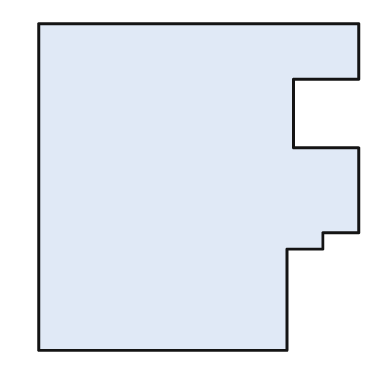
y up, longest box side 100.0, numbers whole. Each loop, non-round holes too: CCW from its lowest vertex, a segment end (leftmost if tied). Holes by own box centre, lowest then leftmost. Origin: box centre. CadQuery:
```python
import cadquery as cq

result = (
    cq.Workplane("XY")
    .moveTo(-49.0, -50.0)
    .lineTo(27.0, -50.0)
    .lineTo(27.0, -19.0)
    .lineTo(38.0, -19.0)
    .lineTo(38.0, -14.0)
    .lineTo(49.0, -14.0)
    .lineTo(49.0, 12.0)
    .lineTo(29.0, 12.0)
    .lineTo(29.0, 33.0)
    .lineTo(49.0, 33.0)
    .lineTo(49.0, 50.0)
    .lineTo(-49.0, 50.0)
    .close()
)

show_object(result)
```